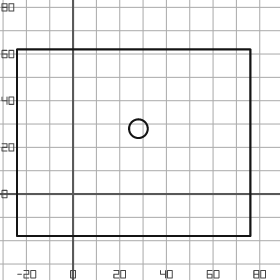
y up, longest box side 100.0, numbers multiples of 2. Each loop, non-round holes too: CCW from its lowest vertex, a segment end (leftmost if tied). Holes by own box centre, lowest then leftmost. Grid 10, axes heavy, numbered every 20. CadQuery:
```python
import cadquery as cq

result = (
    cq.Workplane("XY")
    .moveTo(-24.0, -18.0)
    .lineTo(76.0, -18.0)
    .lineTo(76.0, 62.0)
    .lineTo(-24.0, 62.0)
    .close()
    .moveTo(28.0, 28.0)
    .circle(4.0)
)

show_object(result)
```